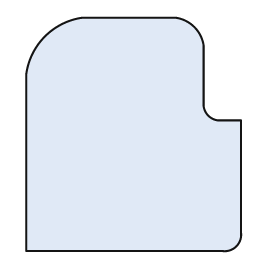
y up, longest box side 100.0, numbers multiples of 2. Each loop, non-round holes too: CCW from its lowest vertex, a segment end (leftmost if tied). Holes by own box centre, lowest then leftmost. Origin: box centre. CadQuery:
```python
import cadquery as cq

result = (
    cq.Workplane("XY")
    .moveTo(-46.0, -50.0)
    .lineTo(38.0, -50.0)
    .threePointArc((44.0, -48.0), (46.0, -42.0))
    .lineTo(46.0, 6.0)
    .lineTo(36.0, 6.0)
    .threePointArc((32.0, 8.0), (30.0, 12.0))
    .lineTo(30.0, 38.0)
    .threePointArc((26.0, 46.0), (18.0, 50.0))
    .lineTo(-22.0, 50.0)
    .threePointArc((-38.0, 42.0), (-46.0, 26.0))
    .close()
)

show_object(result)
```